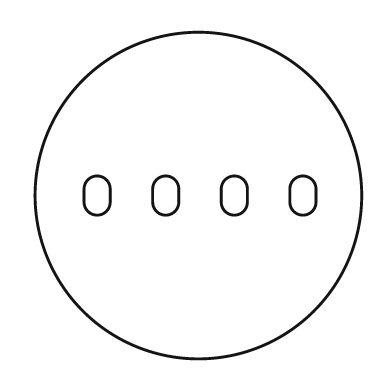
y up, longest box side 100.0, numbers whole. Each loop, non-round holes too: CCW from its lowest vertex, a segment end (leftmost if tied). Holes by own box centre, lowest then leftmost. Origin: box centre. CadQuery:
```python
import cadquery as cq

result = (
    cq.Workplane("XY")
    .moveTo(0.0, 0.0)
    .circle(50.0)
    .moveTo(-35.0, -2.0)
    .threePointArc((-31.0, -6.0), (-27.0, -2.0))
    .lineTo(-27.0, 2.0)
    .threePointArc((-31.0, 6.0), (-35.0, 2.0))
    .close()
    .moveTo(-14.0, -2.0)
    .threePointArc((-10.0, -6.0), (-6.0, -2.0))
    .lineTo(-6.0, 2.0)
    .threePointArc((-10.0, 6.0), (-14.0, 2.0))
    .close()
    .moveTo(7.0, -2.0)
    .threePointArc((11.0, -6.0), (15.0, -2.0))
    .lineTo(15.0, 2.0)
    .threePointArc((11.0, 6.0), (7.0, 2.0))
    .close()
    .moveTo(28.0, -2.0)
    .threePointArc((32.0, -6.0), (36.0, -2.0))
    .lineTo(36.0, 2.0)
    .threePointArc((32.0, 6.0), (28.0, 2.0))
    .close()
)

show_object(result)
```